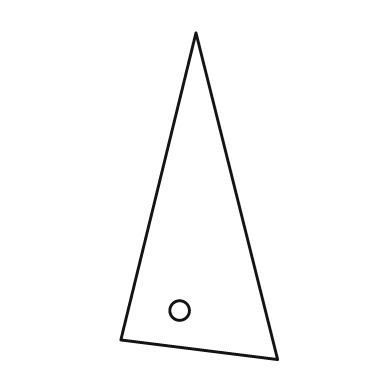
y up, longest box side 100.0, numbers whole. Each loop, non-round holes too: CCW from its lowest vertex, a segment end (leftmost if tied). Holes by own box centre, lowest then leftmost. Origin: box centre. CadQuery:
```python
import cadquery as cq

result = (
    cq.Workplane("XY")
    .moveTo(24.0, -50.0)
    .lineTo(-1.0, 50.0)
    .lineTo(-24.0, -44.0)
    .close()
    .moveTo(-6.0, -35.0)
    .circle(3.0)
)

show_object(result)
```